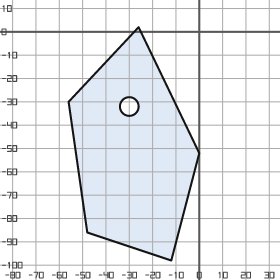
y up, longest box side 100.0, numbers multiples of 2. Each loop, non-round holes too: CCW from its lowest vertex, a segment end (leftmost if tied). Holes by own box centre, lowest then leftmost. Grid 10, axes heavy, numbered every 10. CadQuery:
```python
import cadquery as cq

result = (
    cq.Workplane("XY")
    .moveTo(-12.0, -98.0)
    .lineTo(0.0, -52.0)
    .lineTo(-26.0, 2.0)
    .lineTo(-56.0, -30.0)
    .lineTo(-48.0, -86.0)
    .close()
    .moveTo(-30.0, -32.0)
    .circle(4.0)
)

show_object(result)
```